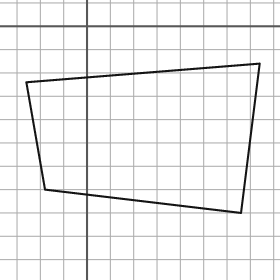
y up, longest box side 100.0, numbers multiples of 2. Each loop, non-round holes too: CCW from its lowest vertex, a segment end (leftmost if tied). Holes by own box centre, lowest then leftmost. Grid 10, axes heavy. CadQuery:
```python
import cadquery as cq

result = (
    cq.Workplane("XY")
    .moveTo(66.0, -80.0)
    .lineTo(74.0, -16.0)
    .lineTo(-26.0, -24.0)
    .lineTo(-18.0, -70.0)
    .close()
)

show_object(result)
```